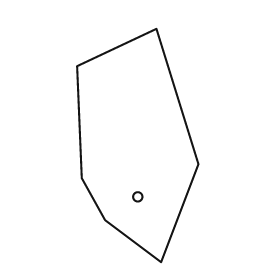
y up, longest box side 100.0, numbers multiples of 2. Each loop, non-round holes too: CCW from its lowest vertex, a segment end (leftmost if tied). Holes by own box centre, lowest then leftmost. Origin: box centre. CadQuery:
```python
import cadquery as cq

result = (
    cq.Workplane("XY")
    .moveTo(10.0, -50.0)
    .lineTo(26.0, -8.0)
    .lineTo(8.0, 50.0)
    .lineTo(-26.0, 34.0)
    .lineTo(-24.0, -14.0)
    .lineTo(-14.0, -32.0)
    .close()
    .moveTo(0.0, -22.0)
    .circle(2.0)
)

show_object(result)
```